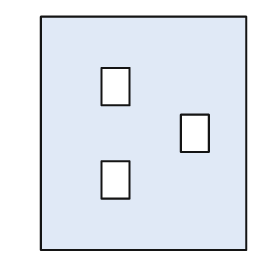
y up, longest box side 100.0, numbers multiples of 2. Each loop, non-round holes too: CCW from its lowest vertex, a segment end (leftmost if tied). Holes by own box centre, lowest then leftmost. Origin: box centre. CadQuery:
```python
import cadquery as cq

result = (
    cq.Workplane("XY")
    .moveTo(-44.0, -50.0)
    .lineTo(44.0, -50.0)
    .lineTo(44.0, 50.0)
    .lineTo(-44.0, 50.0)
    .close()
    .moveTo(-18.0, -28.0)
    .lineTo(-6.0, -28.0)
    .lineTo(-6.0, -12.0)
    .lineTo(-18.0, -12.0)
    .close()
    .moveTo(16.0, -8.0)
    .lineTo(28.0, -8.0)
    .lineTo(28.0, 8.0)
    .lineTo(16.0, 8.0)
    .close()
    .moveTo(-18.0, 12.0)
    .lineTo(-6.0, 12.0)
    .lineTo(-6.0, 28.0)
    .lineTo(-18.0, 28.0)
    .close()
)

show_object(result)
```